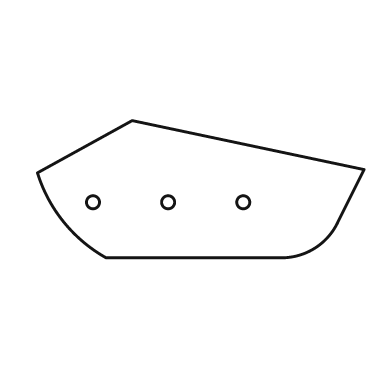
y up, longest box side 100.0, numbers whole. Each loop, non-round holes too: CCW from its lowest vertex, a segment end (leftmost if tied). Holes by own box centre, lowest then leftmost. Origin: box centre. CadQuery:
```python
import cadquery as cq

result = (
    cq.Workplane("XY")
    .moveTo(-29.0, -21.0)
    .lineTo(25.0, -21.0)
    .threePointArc((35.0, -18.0), (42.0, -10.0))
    .lineTo(50.0, 6.0)
    .lineTo(-21.0, 21.0)
    .lineTo(-50.0, 5.0)
    .threePointArc((-42.0, -10.0), (-29.0, -21.0))
    .close()
    .moveTo(-33.0, -4.0)
    .circle(2.0)
    .moveTo(-10.0, -4.0)
    .circle(2.0)
    .moveTo(13.0, -4.0)
    .circle(2.0)
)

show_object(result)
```